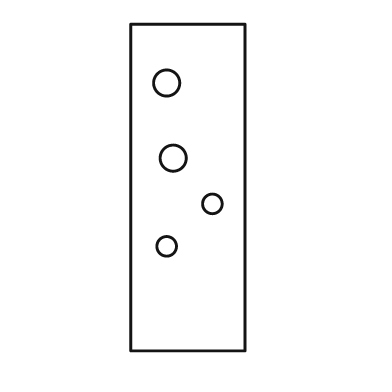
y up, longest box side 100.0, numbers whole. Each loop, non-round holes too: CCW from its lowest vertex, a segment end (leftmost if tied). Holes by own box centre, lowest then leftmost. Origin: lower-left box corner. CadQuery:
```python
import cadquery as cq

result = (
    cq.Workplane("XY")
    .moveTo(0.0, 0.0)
    .lineTo(35.0, 0.0)
    .lineTo(35.0, 100.0)
    .lineTo(0.0, 100.0)
    .close()
    .moveTo(11.0, 32.0)
    .circle(3.0)
    .moveTo(25.0, 45.0)
    .circle(3.0)
    .moveTo(13.0, 59.0)
    .circle(4.0)
    .moveTo(11.0, 82.0)
    .circle(4.0)
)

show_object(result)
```